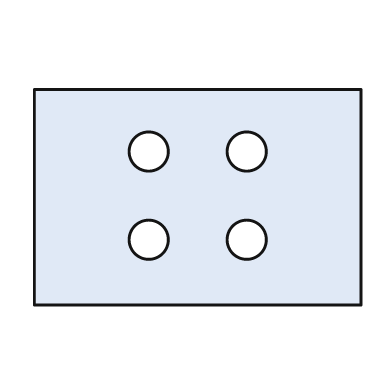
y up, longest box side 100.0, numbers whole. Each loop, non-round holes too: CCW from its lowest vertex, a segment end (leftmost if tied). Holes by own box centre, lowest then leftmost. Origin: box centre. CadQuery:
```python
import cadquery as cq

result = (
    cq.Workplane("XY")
    .moveTo(-50.0, -33.0)
    .lineTo(50.0, -33.0)
    .lineTo(50.0, 33.0)
    .lineTo(-50.0, 33.0)
    .close()
    .moveTo(-15.0, -13.0)
    .circle(6.0)
    .moveTo(15.0, -13.0)
    .circle(6.0)
    .moveTo(-15.0, 14.0)
    .circle(6.0)
    .moveTo(15.0, 14.0)
    .circle(6.0)
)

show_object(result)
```